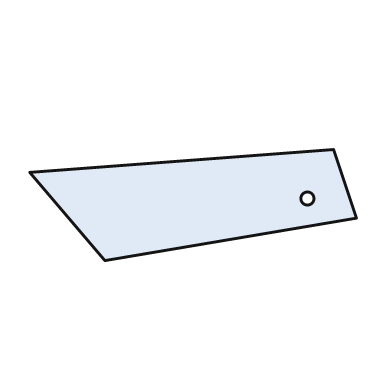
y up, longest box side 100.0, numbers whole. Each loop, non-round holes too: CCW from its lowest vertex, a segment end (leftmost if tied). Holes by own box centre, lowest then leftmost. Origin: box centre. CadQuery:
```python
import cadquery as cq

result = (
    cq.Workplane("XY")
    .moveTo(-27.0, -17.0)
    .lineTo(50.0, -4.0)
    .lineTo(43.0, 17.0)
    .lineTo(-50.0, 10.0)
    .close()
    .moveTo(35.0, 2.0)
    .circle(2.0)
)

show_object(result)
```